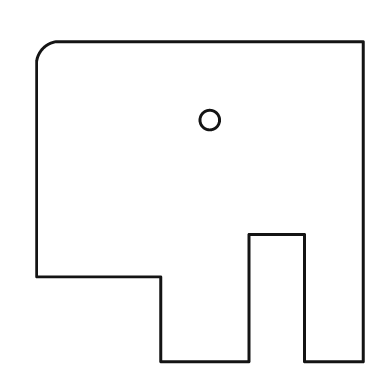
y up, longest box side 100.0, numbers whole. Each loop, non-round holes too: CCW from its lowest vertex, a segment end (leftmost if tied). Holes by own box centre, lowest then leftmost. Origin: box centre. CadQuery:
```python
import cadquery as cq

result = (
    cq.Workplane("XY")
    .moveTo(-12.0, -49.0)
    .lineTo(15.0, -49.0)
    .lineTo(15.0, -10.0)
    .lineTo(32.0, -10.0)
    .lineTo(32.0, -49.0)
    .lineTo(50.0, -49.0)
    .lineTo(50.0, 49.0)
    .lineTo(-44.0, 49.0)
    .threePointArc((-48.0, 47.0), (-50.0, 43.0))
    .lineTo(-50.0, -23.0)
    .lineTo(-12.0, -23.0)
    .close()
    .moveTo(3.0, 25.0)
    .circle(3.0)
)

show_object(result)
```